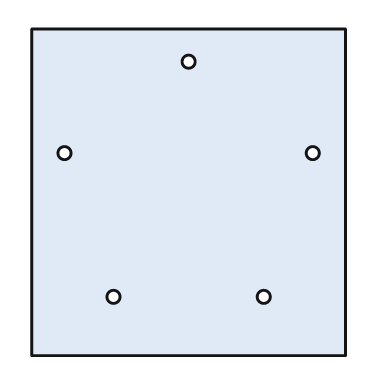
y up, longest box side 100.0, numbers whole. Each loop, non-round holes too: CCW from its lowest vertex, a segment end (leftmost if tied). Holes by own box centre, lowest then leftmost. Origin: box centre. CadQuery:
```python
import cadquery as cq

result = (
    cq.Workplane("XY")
    .moveTo(-48.0, -50.0)
    .lineTo(48.0, -50.0)
    .lineTo(48.0, 50.0)
    .lineTo(-48.0, 50.0)
    .close()
    .moveTo(-23.0, -32.0)
    .circle(2.0)
    .moveTo(23.0, -32.0)
    .circle(2.0)
    .moveTo(-38.0, 12.0)
    .circle(2.0)
    .moveTo(38.0, 12.0)
    .circle(2.0)
    .moveTo(0.0, 40.0)
    .circle(2.0)
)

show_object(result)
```